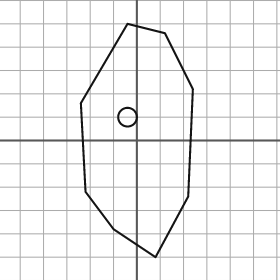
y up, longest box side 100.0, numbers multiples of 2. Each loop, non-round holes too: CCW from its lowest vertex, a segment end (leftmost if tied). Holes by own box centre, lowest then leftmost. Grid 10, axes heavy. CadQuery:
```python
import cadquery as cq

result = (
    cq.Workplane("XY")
    .moveTo(8.0, -50.0)
    .lineTo(22.0, -24.0)
    .lineTo(24.0, 22.0)
    .lineTo(12.0, 46.0)
    .lineTo(-4.0, 50.0)
    .lineTo(-24.0, 16.0)
    .lineTo(-22.0, -22.0)
    .lineTo(-10.0, -38.0)
    .close()
    .moveTo(-4.0, 10.0)
    .circle(4.0)
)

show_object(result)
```